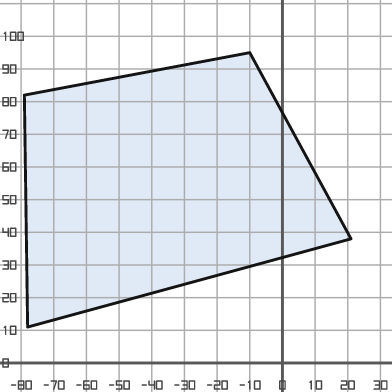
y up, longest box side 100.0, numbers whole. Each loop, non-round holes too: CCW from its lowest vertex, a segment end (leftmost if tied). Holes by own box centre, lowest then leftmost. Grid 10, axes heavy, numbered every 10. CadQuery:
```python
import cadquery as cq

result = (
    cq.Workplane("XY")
    .moveTo(-78.0, 11.0)
    .lineTo(21.0, 38.0)
    .lineTo(-10.0, 95.0)
    .lineTo(-79.0, 82.0)
    .close()
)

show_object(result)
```